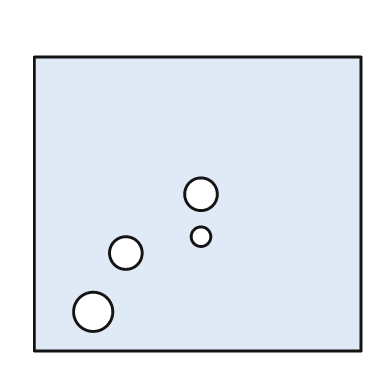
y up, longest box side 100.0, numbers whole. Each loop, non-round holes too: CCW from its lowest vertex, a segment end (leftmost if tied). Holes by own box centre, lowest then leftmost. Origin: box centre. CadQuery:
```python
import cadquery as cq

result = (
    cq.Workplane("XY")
    .moveTo(-50.0, -45.0)
    .lineTo(50.0, -45.0)
    .lineTo(50.0, 45.0)
    .lineTo(-50.0, 45.0)
    .close()
    .moveTo(-32.0, -33.0)
    .circle(6.0)
    .moveTo(-22.0, -15.0)
    .circle(5.0)
    .moveTo(1.0, -10.0)
    .circle(3.0)
    .moveTo(1.0, 3.0)
    .circle(5.0)
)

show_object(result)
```